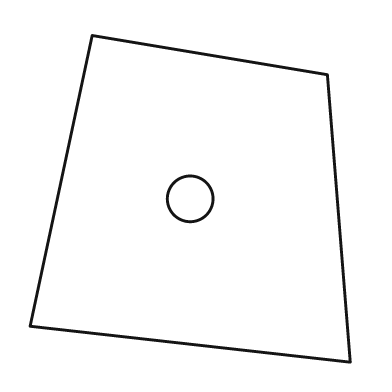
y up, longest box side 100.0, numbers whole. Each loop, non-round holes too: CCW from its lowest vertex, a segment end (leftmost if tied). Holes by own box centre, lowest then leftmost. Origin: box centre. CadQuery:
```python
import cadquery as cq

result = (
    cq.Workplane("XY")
    .moveTo(49.0, -50.0)
    .lineTo(42.0, 38.0)
    .lineTo(-30.0, 50.0)
    .lineTo(-49.0, -39.0)
    .close()
    .moveTo(0.0, 0.0)
    .circle(7.0)
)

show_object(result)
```